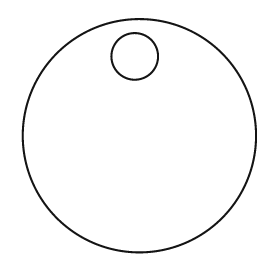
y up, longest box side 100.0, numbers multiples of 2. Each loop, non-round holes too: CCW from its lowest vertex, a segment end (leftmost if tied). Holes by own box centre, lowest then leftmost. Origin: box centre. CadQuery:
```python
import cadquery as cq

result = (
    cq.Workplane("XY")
    .moveTo(0.0, 0.0)
    .circle(50.0)
    .moveTo(-2.0, 34.0)
    .circle(10.0)
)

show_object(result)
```